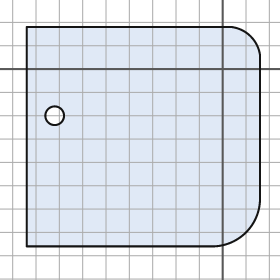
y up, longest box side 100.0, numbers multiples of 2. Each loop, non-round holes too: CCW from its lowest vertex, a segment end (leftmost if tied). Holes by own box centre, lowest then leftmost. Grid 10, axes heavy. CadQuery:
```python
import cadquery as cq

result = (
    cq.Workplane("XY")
    .moveTo(-84.0, -76.0)
    .lineTo(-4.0, -76.0)
    .threePointArc((10.0, -70.0), (16.0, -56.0))
    .lineTo(16.0, 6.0)
    .threePointArc((12.0, 14.0), (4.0, 18.0))
    .lineTo(-84.0, 18.0)
    .close()
    .moveTo(-72.0, -20.0)
    .circle(4.0)
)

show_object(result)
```